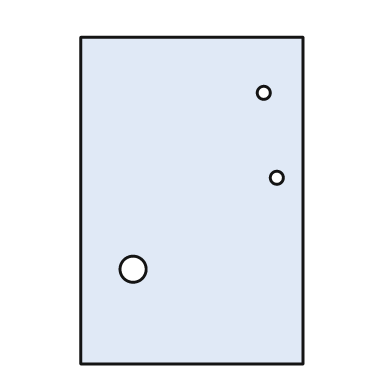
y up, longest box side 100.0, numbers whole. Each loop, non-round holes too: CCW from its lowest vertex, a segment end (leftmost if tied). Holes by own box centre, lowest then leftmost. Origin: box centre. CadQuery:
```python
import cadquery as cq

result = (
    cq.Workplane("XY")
    .moveTo(-34.0, -50.0)
    .lineTo(34.0, -50.0)
    .lineTo(34.0, 50.0)
    .lineTo(-34.0, 50.0)
    .close()
    .moveTo(-18.0, -21.0)
    .circle(4.0)
    .moveTo(26.0, 7.0)
    .circle(2.0)
    .moveTo(22.0, 33.0)
    .circle(2.0)
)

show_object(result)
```